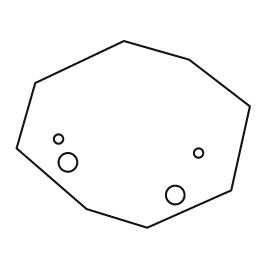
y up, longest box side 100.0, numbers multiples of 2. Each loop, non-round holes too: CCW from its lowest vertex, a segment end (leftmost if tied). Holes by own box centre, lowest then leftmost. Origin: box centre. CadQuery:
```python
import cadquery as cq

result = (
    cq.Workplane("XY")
    .moveTo(6.0, -40.0)
    .lineTo(42.0, -24.0)
    .lineTo(50.0, 12.0)
    .lineTo(24.0, 32.0)
    .lineTo(-4.0, 40.0)
    .lineTo(-42.0, 22.0)
    .lineTo(-50.0, -6.0)
    .lineTo(-20.0, -32.0)
    .close()
    .moveTo(18.0, -26.0)
    .circle(4.0)
    .moveTo(-28.0, -12.0)
    .circle(4.0)
    .moveTo(28.0, -8.0)
    .circle(2.0)
    .moveTo(-32.0, -2.0)
    .circle(2.0)
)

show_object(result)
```